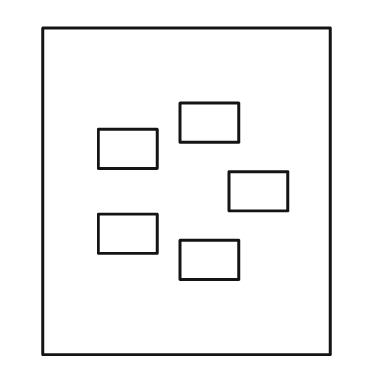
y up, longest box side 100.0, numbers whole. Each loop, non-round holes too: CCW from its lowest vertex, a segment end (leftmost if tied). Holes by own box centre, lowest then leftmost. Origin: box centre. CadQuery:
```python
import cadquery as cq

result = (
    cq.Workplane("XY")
    .moveTo(-44.0, -50.0)
    .lineTo(44.0, -50.0)
    .lineTo(44.0, 50.0)
    .lineTo(-44.0, 50.0)
    .close()
    .moveTo(-2.0, -27.0)
    .lineTo(16.0, -27.0)
    .lineTo(16.0, -15.0)
    .lineTo(-2.0, -15.0)
    .close()
    .moveTo(-27.0, -19.0)
    .lineTo(-9.0, -19.0)
    .lineTo(-9.0, -7.0)
    .lineTo(-27.0, -7.0)
    .close()
    .moveTo(13.0, -6.0)
    .lineTo(31.0, -6.0)
    .lineTo(31.0, 6.0)
    .lineTo(13.0, 6.0)
    .close()
    .moveTo(-27.0, 7.0)
    .lineTo(-9.0, 7.0)
    .lineTo(-9.0, 19.0)
    .lineTo(-27.0, 19.0)
    .close()
    .moveTo(-2.0, 15.0)
    .lineTo(16.0, 15.0)
    .lineTo(16.0, 27.0)
    .lineTo(-2.0, 27.0)
    .close()
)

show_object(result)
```